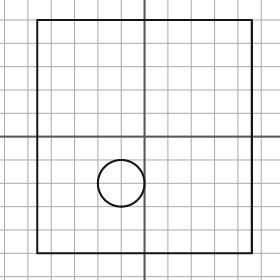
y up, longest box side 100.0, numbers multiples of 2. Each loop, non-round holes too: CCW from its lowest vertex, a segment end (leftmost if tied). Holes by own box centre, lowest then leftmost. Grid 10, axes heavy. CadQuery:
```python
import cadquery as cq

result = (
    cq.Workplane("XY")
    .moveTo(-46.0, -50.0)
    .lineTo(46.0, -50.0)
    .lineTo(46.0, 50.0)
    .lineTo(-46.0, 50.0)
    .close()
    .moveTo(-10.0, -20.0)
    .circle(10.0)
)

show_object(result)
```